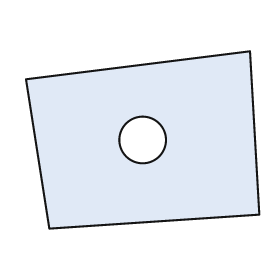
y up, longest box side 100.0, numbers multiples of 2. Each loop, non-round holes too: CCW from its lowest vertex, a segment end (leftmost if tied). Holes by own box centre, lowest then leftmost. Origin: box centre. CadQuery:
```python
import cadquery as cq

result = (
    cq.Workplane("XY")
    .moveTo(-40.0, -38.0)
    .lineTo(50.0, -32.0)
    .lineTo(46.0, 38.0)
    .lineTo(-50.0, 26.0)
    .close()
    .moveTo(0.0, 0.0)
    .circle(10.0)
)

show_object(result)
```